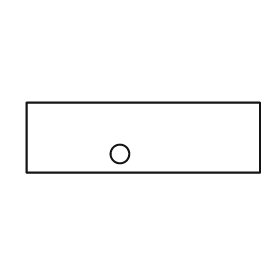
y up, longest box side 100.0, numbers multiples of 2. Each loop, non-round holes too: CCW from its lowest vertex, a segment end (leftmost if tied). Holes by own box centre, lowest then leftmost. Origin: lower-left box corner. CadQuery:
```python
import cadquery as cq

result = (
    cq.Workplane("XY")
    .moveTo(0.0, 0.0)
    .lineTo(100.0, 0.0)
    .lineTo(100.0, 30.0)
    .lineTo(0.0, 30.0)
    .close()
    .moveTo(40.0, 8.0)
    .circle(4.0)
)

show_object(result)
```